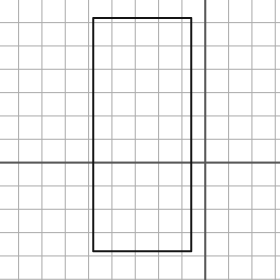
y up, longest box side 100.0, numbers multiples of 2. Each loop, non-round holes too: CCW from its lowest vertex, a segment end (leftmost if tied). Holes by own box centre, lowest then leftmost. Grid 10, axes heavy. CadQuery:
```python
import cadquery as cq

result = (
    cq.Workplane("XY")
    .moveTo(-48.0, -38.0)
    .lineTo(-6.0, -38.0)
    .lineTo(-6.0, 62.0)
    .lineTo(-48.0, 62.0)
    .close()
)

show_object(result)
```